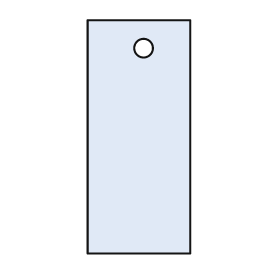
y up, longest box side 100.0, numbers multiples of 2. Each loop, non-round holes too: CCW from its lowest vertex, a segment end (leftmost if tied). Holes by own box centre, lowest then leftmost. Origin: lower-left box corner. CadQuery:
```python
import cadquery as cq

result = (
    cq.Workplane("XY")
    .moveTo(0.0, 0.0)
    .lineTo(44.0, 0.0)
    .lineTo(44.0, 100.0)
    .lineTo(0.0, 100.0)
    .close()
    .moveTo(24.0, 88.0)
    .circle(4.0)
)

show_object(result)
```